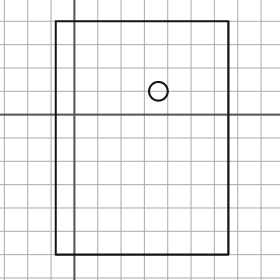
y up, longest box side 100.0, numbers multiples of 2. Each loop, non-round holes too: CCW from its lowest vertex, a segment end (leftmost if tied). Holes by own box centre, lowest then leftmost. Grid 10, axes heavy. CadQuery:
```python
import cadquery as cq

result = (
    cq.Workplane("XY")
    .moveTo(-8.0, -60.0)
    .lineTo(66.0, -60.0)
    .lineTo(66.0, 40.0)
    .lineTo(-8.0, 40.0)
    .close()
    .moveTo(36.0, 10.0)
    .circle(4.0)
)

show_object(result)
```